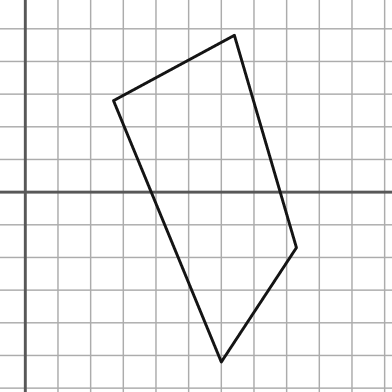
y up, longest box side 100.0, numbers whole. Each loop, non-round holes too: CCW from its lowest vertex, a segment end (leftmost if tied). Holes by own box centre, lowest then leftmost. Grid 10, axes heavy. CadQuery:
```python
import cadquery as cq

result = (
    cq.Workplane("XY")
    .moveTo(60.0, -52.0)
    .lineTo(83.0, -17.0)
    .lineTo(64.0, 48.0)
    .lineTo(27.0, 28.0)
    .close()
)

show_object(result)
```